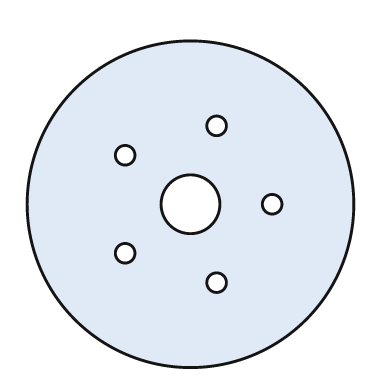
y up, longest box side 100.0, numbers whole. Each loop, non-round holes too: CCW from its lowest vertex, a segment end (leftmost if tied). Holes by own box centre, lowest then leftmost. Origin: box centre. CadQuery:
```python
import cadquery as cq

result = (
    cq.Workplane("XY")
    .moveTo(0.0, 0.0)
    .circle(50.0)
    .moveTo(8.0, -24.0)
    .circle(3.0)
    .moveTo(-20.0, -15.0)
    .circle(3.0)
    .moveTo(0.0, 0.0)
    .circle(9.0)
    .moveTo(25.0, 0.0)
    .circle(3.0)
    .moveTo(-20.0, 15.0)
    .circle(3.0)
    .moveTo(8.0, 24.0)
    .circle(3.0)
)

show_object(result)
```